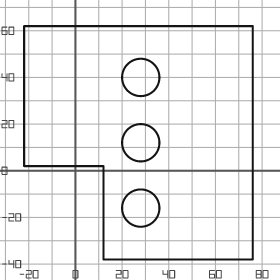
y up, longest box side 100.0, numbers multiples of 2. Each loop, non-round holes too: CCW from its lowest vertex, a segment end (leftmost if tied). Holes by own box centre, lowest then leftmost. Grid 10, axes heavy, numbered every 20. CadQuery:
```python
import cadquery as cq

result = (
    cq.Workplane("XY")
    .moveTo(12.0, -38.0)
    .lineTo(76.0, -38.0)
    .lineTo(76.0, 62.0)
    .lineTo(-22.0, 62.0)
    .lineTo(-22.0, 2.0)
    .lineTo(12.0, 2.0)
    .close()
    .moveTo(28.0, -16.0)
    .circle(8.0)
    .moveTo(28.0, 12.0)
    .circle(8.0)
    .moveTo(28.0, 40.0)
    .circle(8.0)
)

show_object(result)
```